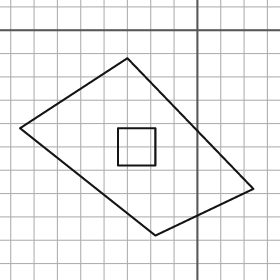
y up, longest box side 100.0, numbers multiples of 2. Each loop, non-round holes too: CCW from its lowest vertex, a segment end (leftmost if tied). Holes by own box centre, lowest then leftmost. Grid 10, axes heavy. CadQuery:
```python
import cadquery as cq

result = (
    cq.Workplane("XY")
    .moveTo(-18.0, -88.0)
    .lineTo(24.0, -68.0)
    .lineTo(-30.0, -12.0)
    .lineTo(-76.0, -42.0)
    .close()
    .moveTo(-34.0, -58.0)
    .lineTo(-18.0, -58.0)
    .lineTo(-18.0, -42.0)
    .lineTo(-34.0, -42.0)
    .close()
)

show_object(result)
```